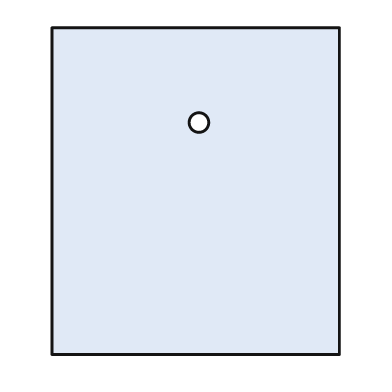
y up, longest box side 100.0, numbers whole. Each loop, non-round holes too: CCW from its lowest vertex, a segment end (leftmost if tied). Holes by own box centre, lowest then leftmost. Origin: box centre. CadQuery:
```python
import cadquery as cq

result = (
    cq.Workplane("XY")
    .moveTo(-44.0, -50.0)
    .lineTo(44.0, -50.0)
    .lineTo(44.0, 50.0)
    .lineTo(-44.0, 50.0)
    .close()
    .moveTo(1.0, 21.0)
    .circle(3.0)
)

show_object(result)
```